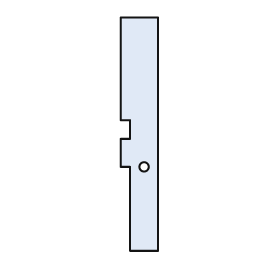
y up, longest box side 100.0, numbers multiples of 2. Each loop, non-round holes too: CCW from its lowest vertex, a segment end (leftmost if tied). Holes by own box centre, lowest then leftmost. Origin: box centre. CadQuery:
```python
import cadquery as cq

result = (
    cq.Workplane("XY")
    .moveTo(-4.0, -50.0)
    .lineTo(8.0, -50.0)
    .lineTo(8.0, 50.0)
    .lineTo(-8.0, 50.0)
    .lineTo(-8.0, 6.0)
    .lineTo(-4.0, 6.0)
    .lineTo(-4.0, -2.0)
    .lineTo(-8.0, -2.0)
    .lineTo(-8.0, -14.0)
    .lineTo(-4.0, -14.0)
    .close()
    .moveTo(2.0, -14.0)
    .circle(2.0)
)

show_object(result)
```